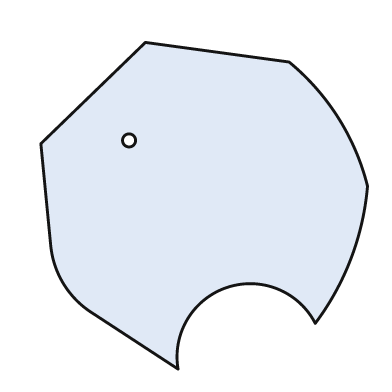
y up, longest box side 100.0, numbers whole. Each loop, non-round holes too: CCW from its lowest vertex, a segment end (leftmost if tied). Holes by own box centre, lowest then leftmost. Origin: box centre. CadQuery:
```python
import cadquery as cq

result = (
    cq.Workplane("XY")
    .moveTo(-8.0, -50.0)
    .threePointArc((7.0, -25.0), (34.0, -36.0))
    .threePointArc((45.0, -16.0), (50.0, 6.0))
    .threePointArc((41.0, 27.0), (26.0, 44.0))
    .lineTo(-18.0, 50.0)
    .lineTo(-50.0, 19.0)
    .lineTo(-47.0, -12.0)
    .threePointArc((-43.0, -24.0), (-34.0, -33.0))
    .close()
    .moveTo(-23.0, 20.0)
    .circle(2.0)
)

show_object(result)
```